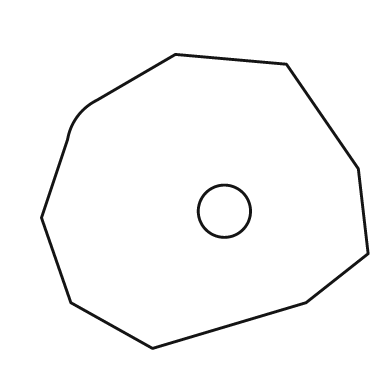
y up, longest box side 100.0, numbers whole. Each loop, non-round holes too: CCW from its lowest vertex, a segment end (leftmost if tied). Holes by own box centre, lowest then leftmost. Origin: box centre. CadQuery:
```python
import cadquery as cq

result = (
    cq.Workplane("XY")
    .moveTo(-16.0, -45.0)
    .lineTo(31.0, -31.0)
    .lineTo(50.0, -16.0)
    .lineTo(47.0, 10.0)
    .lineTo(25.0, 42.0)
    .lineTo(-9.0, 45.0)
    .lineTo(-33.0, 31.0)
    .threePointArc((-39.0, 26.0), (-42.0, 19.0))
    .lineTo(-50.0, -5.0)
    .lineTo(-41.0, -31.0)
    .close()
    .moveTo(6.0, -3.0)
    .circle(8.0)
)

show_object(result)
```